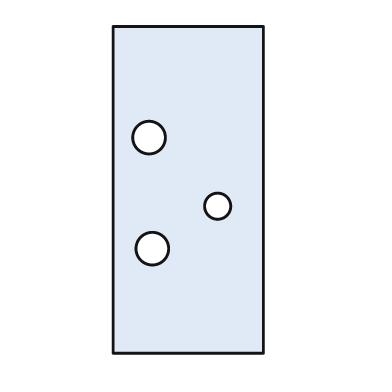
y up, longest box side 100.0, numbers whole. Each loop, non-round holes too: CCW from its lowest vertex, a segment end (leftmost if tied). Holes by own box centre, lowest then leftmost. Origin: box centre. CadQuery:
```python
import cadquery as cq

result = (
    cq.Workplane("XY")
    .moveTo(-23.0, -50.0)
    .lineTo(23.0, -50.0)
    .lineTo(23.0, 50.0)
    .lineTo(-23.0, 50.0)
    .close()
    .moveTo(-11.0, -18.0)
    .circle(5.0)
    .moveTo(9.0, -5.0)
    .circle(4.0)
    .moveTo(-12.0, 16.0)
    .circle(5.0)
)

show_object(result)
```